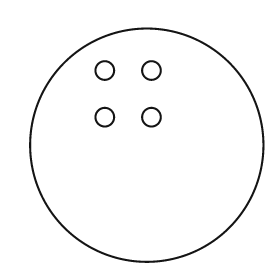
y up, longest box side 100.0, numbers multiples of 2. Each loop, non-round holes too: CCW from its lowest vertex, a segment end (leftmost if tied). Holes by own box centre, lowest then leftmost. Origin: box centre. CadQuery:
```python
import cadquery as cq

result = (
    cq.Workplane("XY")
    .moveTo(0.0, 0.0)
    .circle(50.0)
    .moveTo(-18.0, 12.0)
    .circle(4.0)
    .moveTo(2.0, 12.0)
    .circle(4.0)
    .moveTo(-18.0, 32.0)
    .circle(4.0)
    .moveTo(2.0, 32.0)
    .circle(4.0)
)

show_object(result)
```